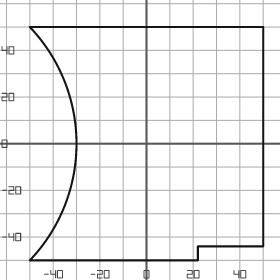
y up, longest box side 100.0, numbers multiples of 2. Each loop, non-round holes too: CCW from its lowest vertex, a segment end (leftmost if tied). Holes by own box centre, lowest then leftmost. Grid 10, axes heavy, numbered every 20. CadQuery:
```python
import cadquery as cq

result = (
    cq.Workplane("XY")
    .moveTo(-50.0, -50.0)
    .lineTo(22.0, -50.0)
    .lineTo(22.0, -44.0)
    .lineTo(50.0, -44.0)
    .lineTo(50.0, 50.0)
    .lineTo(-50.0, 50.0)
    .threePointArc((-30.0, 0.0), (-50.0, -50.0))
    .close()
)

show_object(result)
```